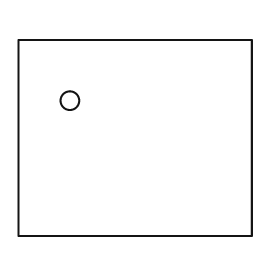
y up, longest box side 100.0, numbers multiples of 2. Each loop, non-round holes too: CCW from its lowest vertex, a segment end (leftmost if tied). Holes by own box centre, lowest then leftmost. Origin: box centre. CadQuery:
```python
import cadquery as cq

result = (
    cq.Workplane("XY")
    .moveTo(-50.0, -42.0)
    .lineTo(50.0, -42.0)
    .lineTo(50.0, 42.0)
    .lineTo(-50.0, 42.0)
    .close()
    .moveTo(-28.0, 16.0)
    .circle(4.0)
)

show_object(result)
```